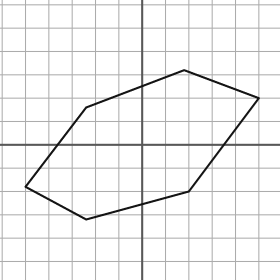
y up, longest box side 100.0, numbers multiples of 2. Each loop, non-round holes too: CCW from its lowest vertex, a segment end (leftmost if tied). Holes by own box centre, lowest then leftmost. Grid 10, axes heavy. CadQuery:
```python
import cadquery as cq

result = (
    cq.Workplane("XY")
    .moveTo(-24.0, -32.0)
    .lineTo(20.0, -20.0)
    .lineTo(50.0, 20.0)
    .lineTo(18.0, 32.0)
    .lineTo(-24.0, 16.0)
    .lineTo(-50.0, -18.0)
    .close()
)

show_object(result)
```